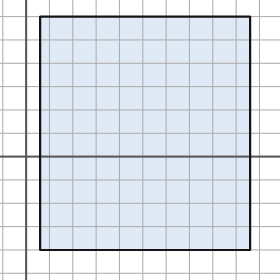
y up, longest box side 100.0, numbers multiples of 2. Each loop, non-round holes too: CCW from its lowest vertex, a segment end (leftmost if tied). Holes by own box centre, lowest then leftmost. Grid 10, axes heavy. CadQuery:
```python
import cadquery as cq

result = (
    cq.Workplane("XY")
    .moveTo(6.0, -40.0)
    .lineTo(96.0, -40.0)
    .lineTo(96.0, 60.0)
    .lineTo(6.0, 60.0)
    .close()
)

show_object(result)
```